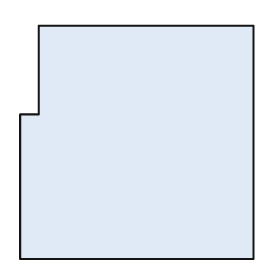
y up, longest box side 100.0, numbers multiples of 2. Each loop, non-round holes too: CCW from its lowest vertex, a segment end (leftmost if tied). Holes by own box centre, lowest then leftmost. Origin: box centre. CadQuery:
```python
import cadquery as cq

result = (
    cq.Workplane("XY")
    .moveTo(-50.0, -50.0)
    .lineTo(50.0, -50.0)
    .lineTo(50.0, 50.0)
    .lineTo(-42.0, 50.0)
    .lineTo(-42.0, 12.0)
    .lineTo(-50.0, 12.0)
    .close()
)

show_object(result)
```